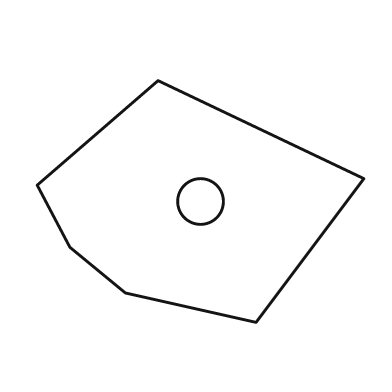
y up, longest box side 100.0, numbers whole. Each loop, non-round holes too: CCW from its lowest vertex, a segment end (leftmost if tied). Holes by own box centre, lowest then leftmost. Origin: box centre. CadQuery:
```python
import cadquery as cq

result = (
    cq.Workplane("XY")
    .moveTo(17.0, -37.0)
    .lineTo(50.0, 7.0)
    .lineTo(-13.0, 37.0)
    .lineTo(-50.0, 5.0)
    .lineTo(-40.0, -14.0)
    .lineTo(-23.0, -28.0)
    .close()
    .moveTo(0.0, 0.0)
    .circle(7.0)
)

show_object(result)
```